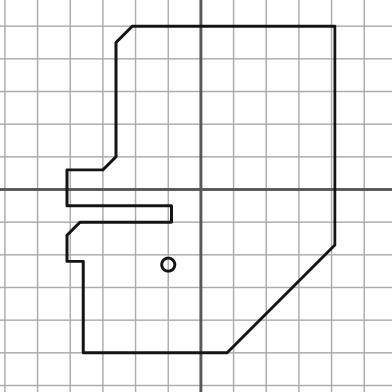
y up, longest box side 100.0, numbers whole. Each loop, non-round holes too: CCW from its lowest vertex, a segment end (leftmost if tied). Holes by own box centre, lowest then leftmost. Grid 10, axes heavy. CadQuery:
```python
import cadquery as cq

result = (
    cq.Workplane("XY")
    .moveTo(-36.0, -50.0)
    .lineTo(8.0, -50.0)
    .lineTo(41.0, -17.0)
    .lineTo(41.0, 50.0)
    .lineTo(-21.0, 50.0)
    .lineTo(-26.0, 45.0)
    .lineTo(-26.0, 10.0)
    .lineTo(-30.0, 6.0)
    .lineTo(-41.0, 6.0)
    .lineTo(-41.0, -5.0)
    .lineTo(-9.0, -5.0)
    .lineTo(-9.0, -10.0)
    .lineTo(-37.0, -10.0)
    .lineTo(-41.0, -14.0)
    .lineTo(-41.0, -22.0)
    .lineTo(-36.0, -22.0)
    .close()
    .moveTo(-10.0, -23.0)
    .circle(2.0)
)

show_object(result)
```